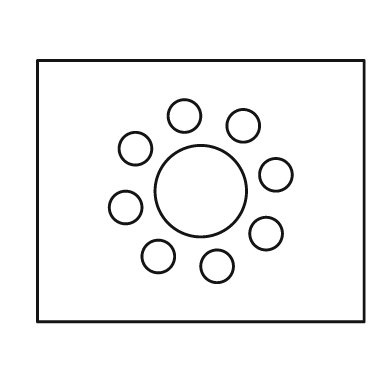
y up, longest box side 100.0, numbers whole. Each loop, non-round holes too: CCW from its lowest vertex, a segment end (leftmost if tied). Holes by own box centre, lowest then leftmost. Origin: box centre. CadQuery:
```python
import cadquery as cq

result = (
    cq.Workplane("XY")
    .moveTo(-50.0, -40.0)
    .lineTo(50.0, -40.0)
    .lineTo(50.0, 40.0)
    .lineTo(-50.0, 40.0)
    .close()
    .moveTo(5.0, -23.0)
    .circle(5.0)
    .moveTo(-13.0, -20.0)
    .circle(5.0)
    .moveTo(20.0, -13.0)
    .circle(5.0)
    .moveTo(-23.0, -5.0)
    .circle(5.0)
    .moveTo(0.0, 0.0)
    .circle(14.0)
    .moveTo(23.0, 5.0)
    .circle(5.0)
    .moveTo(-20.0, 13.0)
    .circle(5.0)
    .moveTo(13.0, 20.0)
    .circle(5.0)
    .moveTo(-5.0, 23.0)
    .circle(5.0)
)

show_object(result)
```